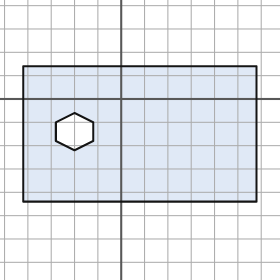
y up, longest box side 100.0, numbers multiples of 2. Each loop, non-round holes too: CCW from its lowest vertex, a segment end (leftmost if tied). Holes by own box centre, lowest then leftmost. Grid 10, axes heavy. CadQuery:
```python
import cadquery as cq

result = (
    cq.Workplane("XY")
    .moveTo(-42.0, -44.0)
    .lineTo(58.0, -44.0)
    .lineTo(58.0, 14.0)
    .lineTo(-42.0, 14.0)
    .close()
    .moveTo(-20.0, -22.0)
    .lineTo(-12.0, -18.0)
    .lineTo(-12.0, -10.0)
    .lineTo(-20.0, -6.0)
    .lineTo(-28.0, -10.0)
    .lineTo(-28.0, -18.0)
    .close()
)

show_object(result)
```